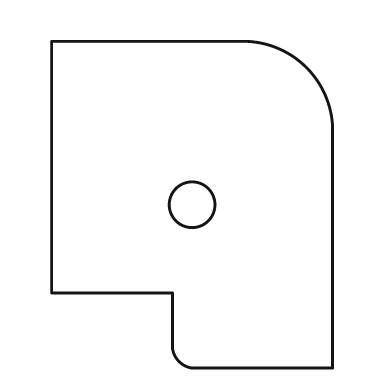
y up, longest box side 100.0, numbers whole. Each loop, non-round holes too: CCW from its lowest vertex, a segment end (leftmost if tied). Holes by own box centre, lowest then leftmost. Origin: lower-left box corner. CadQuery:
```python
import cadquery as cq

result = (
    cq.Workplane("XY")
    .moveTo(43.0, 0.0)
    .lineTo(86.0, 0.0)
    .lineTo(86.0, 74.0)
    .threePointArc((78.0, 92.0), (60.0, 100.0))
    .lineTo(0.0, 100.0)
    .lineTo(0.0, 23.0)
    .lineTo(37.0, 23.0)
    .lineTo(37.0, 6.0)
    .threePointArc((39.0, 2.0), (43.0, 0.0))
    .close()
    .moveTo(43.0, 50.0)
    .circle(7.0)
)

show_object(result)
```